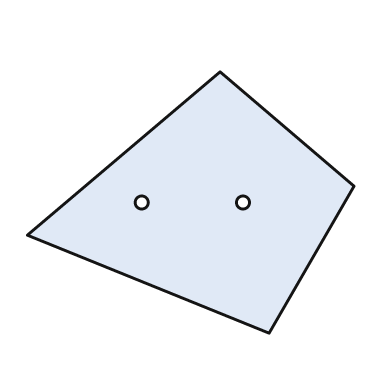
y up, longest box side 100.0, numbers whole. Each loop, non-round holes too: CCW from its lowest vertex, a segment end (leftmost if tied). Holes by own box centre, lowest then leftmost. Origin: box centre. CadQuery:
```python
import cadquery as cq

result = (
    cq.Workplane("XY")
    .moveTo(24.0, -40.0)
    .lineTo(50.0, 5.0)
    .lineTo(9.0, 40.0)
    .lineTo(-50.0, -10.0)
    .close()
    .moveTo(-15.0, 0.0)
    .circle(2.0)
    .moveTo(16.0, 0.0)
    .circle(2.0)
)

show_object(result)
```